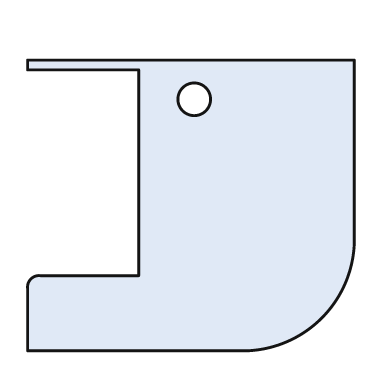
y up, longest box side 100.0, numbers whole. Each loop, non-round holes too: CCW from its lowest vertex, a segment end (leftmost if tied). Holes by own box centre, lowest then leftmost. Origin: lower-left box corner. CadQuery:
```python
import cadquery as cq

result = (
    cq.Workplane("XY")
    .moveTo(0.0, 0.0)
    .lineTo(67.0, 0.0)
    .threePointArc((90.0, 10.0), (100.0, 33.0))
    .lineTo(100.0, 89.0)
    .lineTo(0.0, 89.0)
    .lineTo(0.0, 86.0)
    .lineTo(34.0, 86.0)
    .lineTo(34.0, 23.0)
    .lineTo(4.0, 23.0)
    .threePointArc((1.0, 22.0), (0.0, 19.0))
    .close()
    .moveTo(51.0, 77.0)
    .circle(5.0)
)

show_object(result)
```